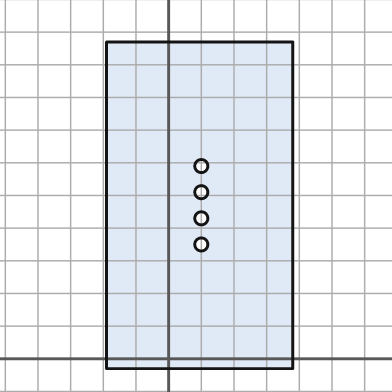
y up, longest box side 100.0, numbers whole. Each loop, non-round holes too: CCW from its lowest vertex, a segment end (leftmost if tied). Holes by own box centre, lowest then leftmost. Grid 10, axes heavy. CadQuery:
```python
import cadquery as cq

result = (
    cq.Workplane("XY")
    .moveTo(-19.0, -3.0)
    .lineTo(38.0, -3.0)
    .lineTo(38.0, 97.0)
    .lineTo(-19.0, 97.0)
    .close()
    .moveTo(10.0, 35.0)
    .circle(2.0)
    .moveTo(10.0, 43.0)
    .circle(2.0)
    .moveTo(10.0, 51.0)
    .circle(2.0)
    .moveTo(10.0, 59.0)
    .circle(2.0)
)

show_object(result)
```